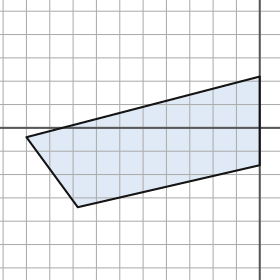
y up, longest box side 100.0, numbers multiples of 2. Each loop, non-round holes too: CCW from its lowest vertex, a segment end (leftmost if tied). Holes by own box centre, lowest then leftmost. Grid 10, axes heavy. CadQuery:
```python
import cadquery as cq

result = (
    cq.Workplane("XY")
    .moveTo(-78.0, -34.0)
    .lineTo(0.0, -16.0)
    .lineTo(0.0, 22.0)
    .lineTo(-100.0, -4.0)
    .close()
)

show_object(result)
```